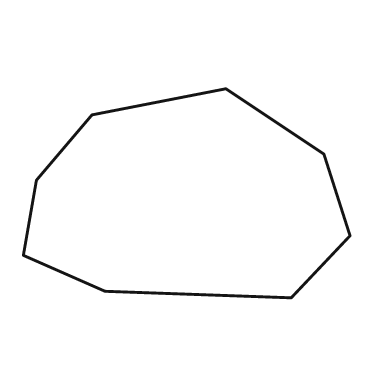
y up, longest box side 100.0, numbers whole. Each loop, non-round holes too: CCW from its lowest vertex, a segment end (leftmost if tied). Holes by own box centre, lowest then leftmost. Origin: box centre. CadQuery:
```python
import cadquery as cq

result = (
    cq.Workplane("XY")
    .moveTo(32.0, -32.0)
    .lineTo(50.0, -13.0)
    .lineTo(42.0, 12.0)
    .lineTo(12.0, 32.0)
    .lineTo(-29.0, 24.0)
    .lineTo(-46.0, 4.0)
    .lineTo(-50.0, -19.0)
    .lineTo(-25.0, -30.0)
    .close()
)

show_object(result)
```